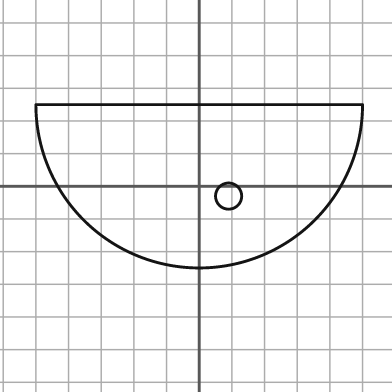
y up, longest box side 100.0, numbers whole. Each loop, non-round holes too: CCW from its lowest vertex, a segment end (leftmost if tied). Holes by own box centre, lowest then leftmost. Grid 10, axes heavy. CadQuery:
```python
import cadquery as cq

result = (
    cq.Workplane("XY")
    .moveTo(-50.0, 25.0)
    .threePointArc((0.0, -25.0), (50.0, 25.0))
    .close()
    .moveTo(9.0, -3.0)
    .circle(4.0)
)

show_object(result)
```